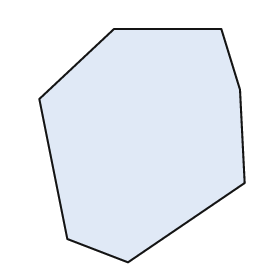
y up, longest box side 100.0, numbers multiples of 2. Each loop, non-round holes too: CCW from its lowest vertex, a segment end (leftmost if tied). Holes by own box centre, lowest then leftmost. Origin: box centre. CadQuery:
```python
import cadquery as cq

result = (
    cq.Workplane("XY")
    .moveTo(-6.0, -50.0)
    .lineTo(44.0, -16.0)
    .lineTo(42.0, 24.0)
    .lineTo(34.0, 50.0)
    .lineTo(-12.0, 50.0)
    .lineTo(-44.0, 20.0)
    .lineTo(-32.0, -40.0)
    .close()
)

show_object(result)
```